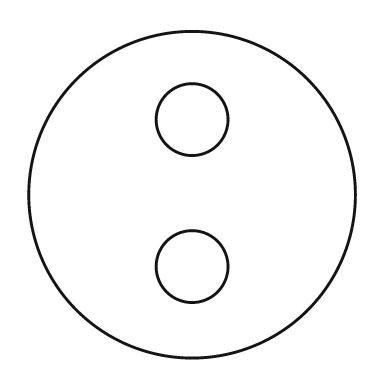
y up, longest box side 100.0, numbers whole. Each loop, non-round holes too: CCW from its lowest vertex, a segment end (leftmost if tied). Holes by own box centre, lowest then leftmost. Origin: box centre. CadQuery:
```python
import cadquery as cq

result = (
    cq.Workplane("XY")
    .moveTo(0.0, 0.0)
    .circle(50.0)
    .moveTo(0.0, -22.0)
    .circle(11.0)
    .moveTo(0.0, 23.0)
    .circle(11.0)
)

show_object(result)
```